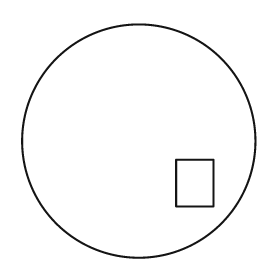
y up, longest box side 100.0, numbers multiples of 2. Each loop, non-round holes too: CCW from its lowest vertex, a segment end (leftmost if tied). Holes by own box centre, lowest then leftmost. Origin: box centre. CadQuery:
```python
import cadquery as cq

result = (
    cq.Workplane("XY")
    .moveTo(0.0, 0.0)
    .circle(50.0)
    .moveTo(16.0, -28.0)
    .lineTo(32.0, -28.0)
    .lineTo(32.0, -8.0)
    .lineTo(16.0, -8.0)
    .close()
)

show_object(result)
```